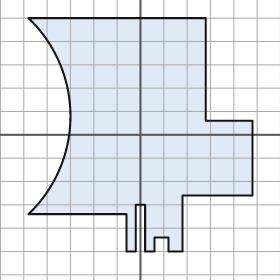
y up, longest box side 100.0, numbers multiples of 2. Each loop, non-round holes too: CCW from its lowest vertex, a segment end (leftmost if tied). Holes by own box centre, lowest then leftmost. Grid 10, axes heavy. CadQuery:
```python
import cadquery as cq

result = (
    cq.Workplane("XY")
    .moveTo(-6.0, -50.0)
    .lineTo(-2.0, -50.0)
    .lineTo(-2.0, -30.0)
    .lineTo(2.0, -30.0)
    .lineTo(2.0, -50.0)
    .lineTo(6.0, -50.0)
    .lineTo(6.0, -44.0)
    .lineTo(12.0, -44.0)
    .lineTo(12.0, -50.0)
    .lineTo(18.0, -50.0)
    .lineTo(18.0, -26.0)
    .lineTo(48.0, -26.0)
    .lineTo(48.0, 6.0)
    .lineTo(28.0, 6.0)
    .lineTo(28.0, 50.0)
    .lineTo(-48.0, 50.0)
    .threePointArc((-30.0, 8.0), (-48.0, -34.0))
    .lineTo(-6.0, -34.0)
    .close()
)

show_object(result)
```